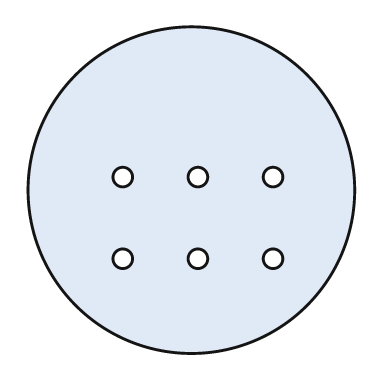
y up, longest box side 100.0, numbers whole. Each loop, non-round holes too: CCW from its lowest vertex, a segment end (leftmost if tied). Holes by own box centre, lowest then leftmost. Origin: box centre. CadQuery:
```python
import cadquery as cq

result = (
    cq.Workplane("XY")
    .moveTo(0.0, 0.0)
    .circle(50.0)
    .moveTo(-21.0, -21.0)
    .circle(3.0)
    .moveTo(2.0, -21.0)
    .circle(3.0)
    .moveTo(25.0, -21.0)
    .circle(3.0)
    .moveTo(-21.0, 4.0)
    .circle(3.0)
    .moveTo(2.0, 4.0)
    .circle(3.0)
    .moveTo(25.0, 4.0)
    .circle(3.0)
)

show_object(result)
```